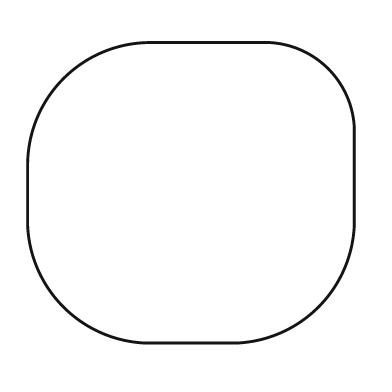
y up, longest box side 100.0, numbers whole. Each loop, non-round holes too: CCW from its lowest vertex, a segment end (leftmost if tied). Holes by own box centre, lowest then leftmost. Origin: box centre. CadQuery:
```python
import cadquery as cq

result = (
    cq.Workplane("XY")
    .moveTo(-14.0, -46.0)
    .lineTo(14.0, -46.0)
    .threePointArc((39.0, -35.0), (50.0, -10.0))
    .lineTo(50.0, 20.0)
    .threePointArc((42.0, 38.0), (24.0, 46.0))
    .lineTo(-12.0, 46.0)
    .threePointArc((-39.0, 35.0), (-50.0, 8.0))
    .lineTo(-50.0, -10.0)
    .threePointArc((-39.0, -35.0), (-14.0, -46.0))
    .close()
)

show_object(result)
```